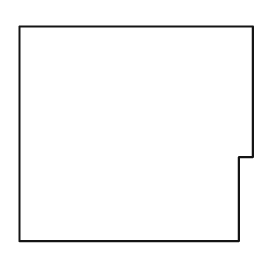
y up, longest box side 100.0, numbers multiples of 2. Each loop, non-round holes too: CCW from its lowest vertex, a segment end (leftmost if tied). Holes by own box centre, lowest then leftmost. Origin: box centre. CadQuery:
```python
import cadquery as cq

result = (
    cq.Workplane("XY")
    .moveTo(-50.0, -46.0)
    .lineTo(44.0, -46.0)
    .lineTo(44.0, -10.0)
    .lineTo(50.0, -10.0)
    .lineTo(50.0, 46.0)
    .lineTo(-50.0, 46.0)
    .close()
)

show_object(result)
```